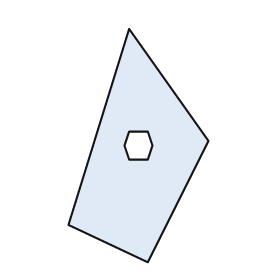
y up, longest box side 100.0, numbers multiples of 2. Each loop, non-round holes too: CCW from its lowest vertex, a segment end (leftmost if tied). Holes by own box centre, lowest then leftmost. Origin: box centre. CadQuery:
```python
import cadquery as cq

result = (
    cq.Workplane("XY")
    .moveTo(4.0, -50.0)
    .lineTo(30.0, 2.0)
    .lineTo(-4.0, 50.0)
    .lineTo(-30.0, -34.0)
    .close()
    .moveTo(-4.0, -6.0)
    .lineTo(4.0, -6.0)
    .lineTo(6.0, 0.0)
    .lineTo(4.0, 6.0)
    .lineTo(-4.0, 6.0)
    .lineTo(-6.0, 0.0)
    .close()
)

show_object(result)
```